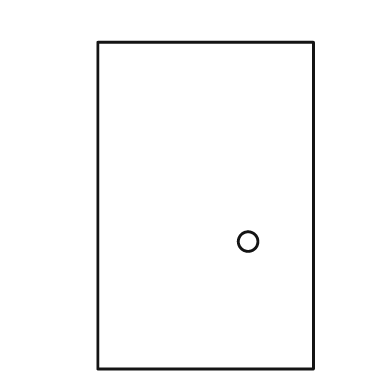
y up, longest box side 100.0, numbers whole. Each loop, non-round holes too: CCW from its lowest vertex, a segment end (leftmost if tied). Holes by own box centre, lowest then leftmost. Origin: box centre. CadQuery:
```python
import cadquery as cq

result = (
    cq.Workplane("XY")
    .moveTo(-33.0, -50.0)
    .lineTo(33.0, -50.0)
    .lineTo(33.0, 50.0)
    .lineTo(-33.0, 50.0)
    .close()
    .moveTo(13.0, -11.0)
    .circle(3.0)
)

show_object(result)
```